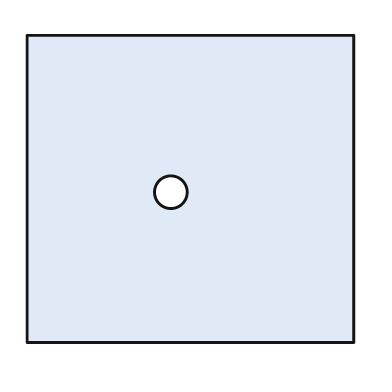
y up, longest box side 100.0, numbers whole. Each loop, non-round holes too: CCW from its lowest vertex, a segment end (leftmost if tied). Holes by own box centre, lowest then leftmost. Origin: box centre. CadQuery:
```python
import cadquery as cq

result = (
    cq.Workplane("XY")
    .moveTo(-50.0, -47.0)
    .lineTo(50.0, -47.0)
    .lineTo(50.0, 47.0)
    .lineTo(-50.0, 47.0)
    .close()
    .moveTo(-6.0, -1.0)
    .circle(5.0)
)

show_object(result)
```